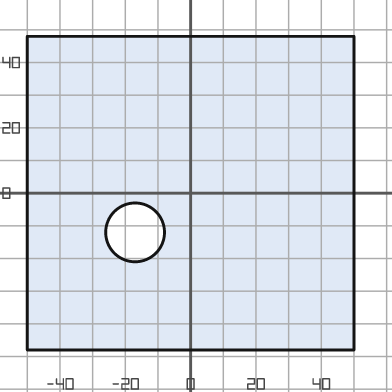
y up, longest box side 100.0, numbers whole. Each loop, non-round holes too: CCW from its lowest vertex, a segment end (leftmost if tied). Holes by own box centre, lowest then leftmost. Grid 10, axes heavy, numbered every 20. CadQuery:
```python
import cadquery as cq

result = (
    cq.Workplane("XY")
    .moveTo(-50.0, -48.0)
    .lineTo(50.0, -48.0)
    .lineTo(50.0, 48.0)
    .lineTo(-50.0, 48.0)
    .close()
    .moveTo(-17.0, -12.0)
    .circle(9.0)
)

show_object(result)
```